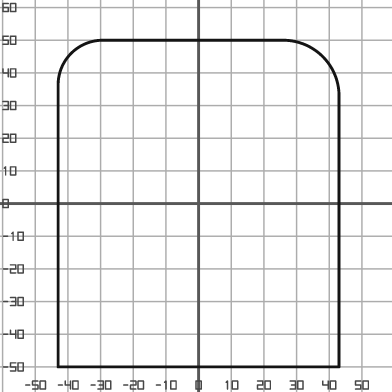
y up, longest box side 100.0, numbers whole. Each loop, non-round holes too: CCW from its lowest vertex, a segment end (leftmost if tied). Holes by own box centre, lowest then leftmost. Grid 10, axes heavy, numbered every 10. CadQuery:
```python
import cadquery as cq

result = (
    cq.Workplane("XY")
    .moveTo(-43.0, -50.0)
    .lineTo(43.0, -50.0)
    .lineTo(43.0, 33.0)
    .threePointArc((38.0, 45.0), (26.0, 50.0))
    .lineTo(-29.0, 50.0)
    .threePointArc((-39.0, 46.0), (-43.0, 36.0))
    .close()
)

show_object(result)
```